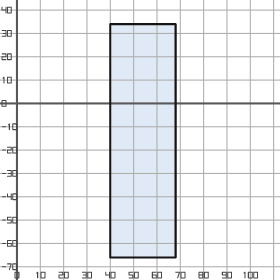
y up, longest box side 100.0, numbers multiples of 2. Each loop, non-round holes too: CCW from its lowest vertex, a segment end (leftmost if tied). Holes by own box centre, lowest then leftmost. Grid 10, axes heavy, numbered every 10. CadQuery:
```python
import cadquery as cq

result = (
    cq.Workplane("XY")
    .moveTo(40.0, -66.0)
    .lineTo(68.0, -66.0)
    .lineTo(68.0, 34.0)
    .lineTo(40.0, 34.0)
    .close()
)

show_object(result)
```